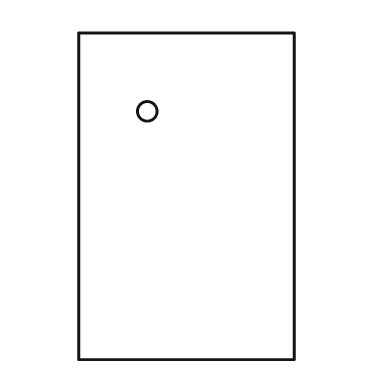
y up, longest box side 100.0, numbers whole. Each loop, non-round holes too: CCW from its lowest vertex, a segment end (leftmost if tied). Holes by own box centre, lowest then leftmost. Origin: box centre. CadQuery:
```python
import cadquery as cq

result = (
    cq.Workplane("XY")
    .moveTo(-33.0, -50.0)
    .lineTo(33.0, -50.0)
    .lineTo(33.0, 50.0)
    .lineTo(-33.0, 50.0)
    .close()
    .moveTo(-12.0, 26.0)
    .circle(3.0)
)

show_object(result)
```